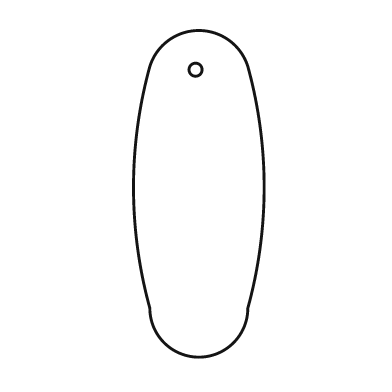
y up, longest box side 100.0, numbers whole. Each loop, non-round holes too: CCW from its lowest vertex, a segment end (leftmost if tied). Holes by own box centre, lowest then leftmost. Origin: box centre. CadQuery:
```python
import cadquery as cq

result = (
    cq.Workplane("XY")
    .moveTo(-15.0, -35.0)
    .threePointArc((0.0, -50.0), (15.0, -35.0))
    .threePointArc((20.0, 2.0), (15.0, 39.0))
    .threePointArc((0.0, 50.0), (-15.0, 39.0))
    .threePointArc((-20.0, 2.0), (-15.0, -35.0))
    .close()
    .moveTo(-1.0, 38.0)
    .circle(2.0)
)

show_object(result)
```